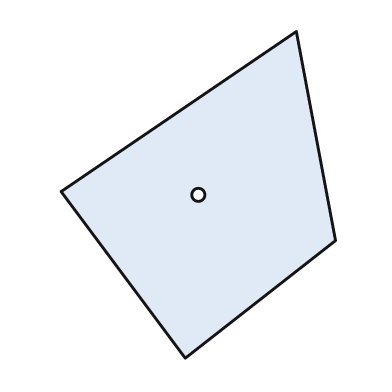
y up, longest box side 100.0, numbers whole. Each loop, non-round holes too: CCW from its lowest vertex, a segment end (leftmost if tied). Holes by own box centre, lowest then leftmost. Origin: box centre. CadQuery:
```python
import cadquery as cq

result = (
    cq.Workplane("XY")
    .moveTo(-4.0, -50.0)
    .lineTo(42.0, -14.0)
    .lineTo(30.0, 50.0)
    .lineTo(-42.0, 1.0)
    .close()
    .moveTo(0.0, 0.0)
    .circle(2.0)
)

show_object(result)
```